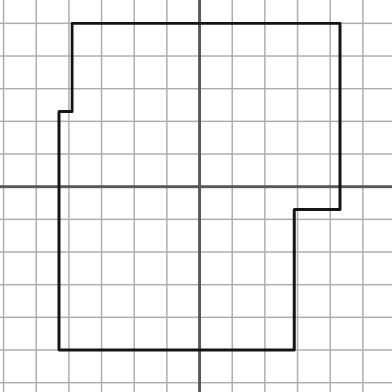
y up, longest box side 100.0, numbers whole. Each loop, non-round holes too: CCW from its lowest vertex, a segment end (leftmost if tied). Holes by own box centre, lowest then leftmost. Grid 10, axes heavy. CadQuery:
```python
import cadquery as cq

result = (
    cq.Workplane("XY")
    .moveTo(-43.0, -50.0)
    .lineTo(29.0, -50.0)
    .lineTo(29.0, -7.0)
    .lineTo(43.0, -7.0)
    .lineTo(43.0, 50.0)
    .lineTo(-39.0, 50.0)
    .lineTo(-39.0, 23.0)
    .lineTo(-43.0, 23.0)
    .close()
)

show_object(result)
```